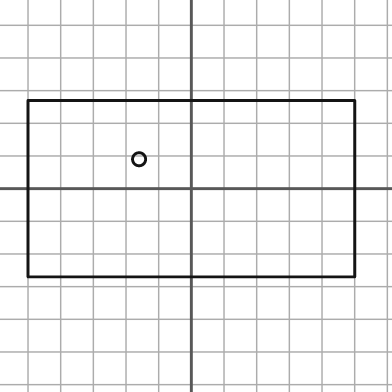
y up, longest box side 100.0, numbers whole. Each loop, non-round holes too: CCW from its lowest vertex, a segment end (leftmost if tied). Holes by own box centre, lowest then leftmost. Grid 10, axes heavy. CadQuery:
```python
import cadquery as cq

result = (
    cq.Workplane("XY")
    .moveTo(-50.0, -27.0)
    .lineTo(50.0, -27.0)
    .lineTo(50.0, 27.0)
    .lineTo(-50.0, 27.0)
    .close()
    .moveTo(-16.0, 9.0)
    .circle(2.0)
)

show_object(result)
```